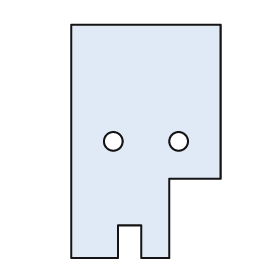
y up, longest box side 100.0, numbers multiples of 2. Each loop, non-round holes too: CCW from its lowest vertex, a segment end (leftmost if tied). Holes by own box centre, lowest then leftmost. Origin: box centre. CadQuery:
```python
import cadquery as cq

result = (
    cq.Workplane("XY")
    .moveTo(-32.0, -50.0)
    .lineTo(-12.0, -50.0)
    .lineTo(-12.0, -36.0)
    .lineTo(-2.0, -36.0)
    .lineTo(-2.0, -50.0)
    .lineTo(10.0, -50.0)
    .lineTo(10.0, -16.0)
    .lineTo(32.0, -16.0)
    .lineTo(32.0, 50.0)
    .lineTo(-32.0, 50.0)
    .close()
    .moveTo(-14.0, 0.0)
    .circle(4.0)
    .moveTo(14.0, 0.0)
    .circle(4.0)
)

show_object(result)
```